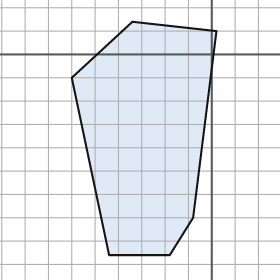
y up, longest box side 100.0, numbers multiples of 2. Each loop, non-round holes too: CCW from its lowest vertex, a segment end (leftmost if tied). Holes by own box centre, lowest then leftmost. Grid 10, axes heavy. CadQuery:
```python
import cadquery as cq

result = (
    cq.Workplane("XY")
    .moveTo(-44.0, -86.0)
    .lineTo(-18.0, -86.0)
    .lineTo(-8.0, -70.0)
    .lineTo(2.0, 10.0)
    .lineTo(-34.0, 14.0)
    .lineTo(-60.0, -10.0)
    .close()
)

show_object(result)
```